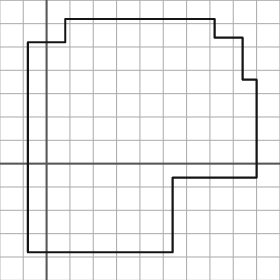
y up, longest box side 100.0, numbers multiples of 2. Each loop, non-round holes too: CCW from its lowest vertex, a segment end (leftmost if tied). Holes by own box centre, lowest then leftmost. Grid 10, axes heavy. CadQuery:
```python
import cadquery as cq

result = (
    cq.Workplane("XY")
    .moveTo(-8.0, -38.0)
    .lineTo(54.0, -38.0)
    .lineTo(54.0, -6.0)
    .lineTo(90.0, -6.0)
    .lineTo(90.0, 36.0)
    .lineTo(84.0, 36.0)
    .lineTo(84.0, 54.0)
    .lineTo(72.0, 54.0)
    .lineTo(72.0, 62.0)
    .lineTo(8.0, 62.0)
    .lineTo(8.0, 52.0)
    .lineTo(-8.0, 52.0)
    .close()
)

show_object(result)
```